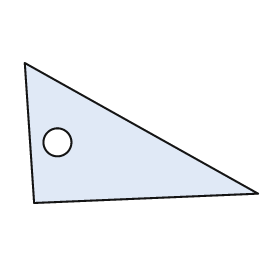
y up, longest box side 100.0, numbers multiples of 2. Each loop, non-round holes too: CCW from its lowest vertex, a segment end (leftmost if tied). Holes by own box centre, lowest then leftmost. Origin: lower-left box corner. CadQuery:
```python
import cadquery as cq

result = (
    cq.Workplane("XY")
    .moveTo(4.0, 0.0)
    .lineTo(100.0, 4.0)
    .lineTo(0.0, 60.0)
    .close()
    .moveTo(14.0, 26.0)
    .circle(6.0)
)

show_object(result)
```